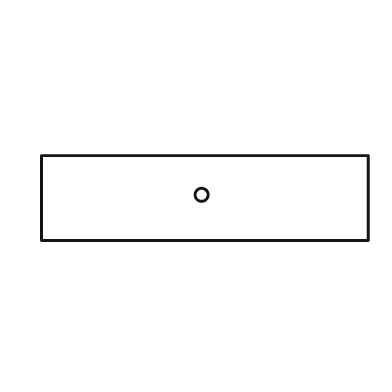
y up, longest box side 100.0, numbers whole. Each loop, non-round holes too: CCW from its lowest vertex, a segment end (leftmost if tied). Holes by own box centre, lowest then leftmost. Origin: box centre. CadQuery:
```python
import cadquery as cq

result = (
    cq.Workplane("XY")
    .moveTo(-50.0, -13.0)
    .lineTo(50.0, -13.0)
    .lineTo(50.0, 13.0)
    .lineTo(-50.0, 13.0)
    .close()
    .moveTo(-1.0, 1.0)
    .circle(2.0)
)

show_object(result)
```